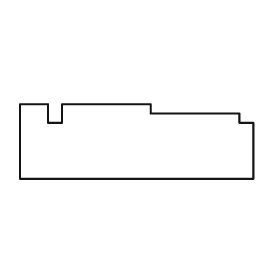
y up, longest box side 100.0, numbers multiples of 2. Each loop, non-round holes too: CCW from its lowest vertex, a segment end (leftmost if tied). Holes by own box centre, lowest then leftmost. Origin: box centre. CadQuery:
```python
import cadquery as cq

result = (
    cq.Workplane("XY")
    .moveTo(-50.0, -16.0)
    .lineTo(50.0, -16.0)
    .lineTo(50.0, 8.0)
    .lineTo(44.0, 8.0)
    .lineTo(44.0, 12.0)
    .lineTo(6.0, 12.0)
    .lineTo(6.0, 16.0)
    .lineTo(-32.0, 16.0)
    .lineTo(-32.0, 8.0)
    .lineTo(-38.0, 8.0)
    .lineTo(-38.0, 16.0)
    .lineTo(-50.0, 16.0)
    .close()
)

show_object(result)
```